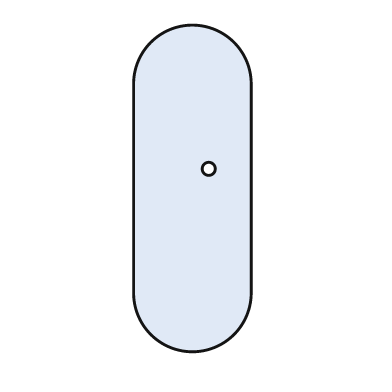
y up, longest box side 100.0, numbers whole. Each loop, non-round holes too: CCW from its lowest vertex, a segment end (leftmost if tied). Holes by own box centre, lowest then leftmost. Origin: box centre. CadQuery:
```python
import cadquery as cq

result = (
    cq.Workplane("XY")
    .moveTo(-18.0, -32.0)
    .threePointArc((0.0, -50.0), (18.0, -32.0))
    .lineTo(18.0, 32.0)
    .threePointArc((0.0, 50.0), (-18.0, 32.0))
    .close()
    .moveTo(5.0, 6.0)
    .circle(2.0)
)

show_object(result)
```